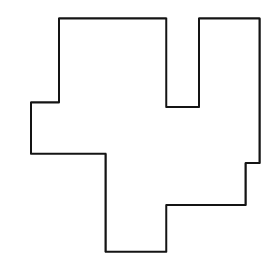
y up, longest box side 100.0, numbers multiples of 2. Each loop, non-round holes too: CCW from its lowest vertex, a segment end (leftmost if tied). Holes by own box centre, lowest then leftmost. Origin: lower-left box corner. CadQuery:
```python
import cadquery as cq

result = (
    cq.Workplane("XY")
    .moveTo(32.0, 0.0)
    .lineTo(58.0, 0.0)
    .lineTo(58.0, 20.0)
    .lineTo(92.0, 20.0)
    .lineTo(92.0, 38.0)
    .lineTo(98.0, 38.0)
    .lineTo(98.0, 100.0)
    .lineTo(72.0, 100.0)
    .lineTo(72.0, 62.0)
    .lineTo(58.0, 62.0)
    .lineTo(58.0, 100.0)
    .lineTo(12.0, 100.0)
    .lineTo(12.0, 64.0)
    .lineTo(0.0, 64.0)
    .lineTo(0.0, 42.0)
    .lineTo(32.0, 42.0)
    .close()
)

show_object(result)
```